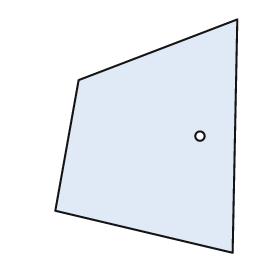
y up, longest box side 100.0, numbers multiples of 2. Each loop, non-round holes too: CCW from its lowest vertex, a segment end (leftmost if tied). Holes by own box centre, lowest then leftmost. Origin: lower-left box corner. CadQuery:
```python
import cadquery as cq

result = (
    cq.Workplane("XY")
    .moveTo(76.0, 0.0)
    .lineTo(78.0, 100.0)
    .lineTo(10.0, 74.0)
    .lineTo(0.0, 18.0)
    .close()
    .moveTo(62.0, 50.0)
    .circle(2.0)
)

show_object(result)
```